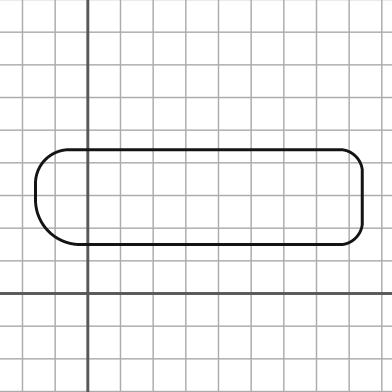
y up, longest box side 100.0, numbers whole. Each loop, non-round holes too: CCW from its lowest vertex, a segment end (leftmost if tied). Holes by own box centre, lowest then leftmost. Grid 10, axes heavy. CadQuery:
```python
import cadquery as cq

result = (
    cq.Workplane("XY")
    .moveTo(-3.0, 15.0)
    .lineTo(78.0, 15.0)
    .threePointArc((82.0, 17.0), (84.0, 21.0))
    .lineTo(84.0, 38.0)
    .threePointArc((82.0, 42.0), (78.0, 44.0))
    .lineTo(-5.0, 44.0)
    .threePointArc((-13.0, 41.0), (-16.0, 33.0))
    .lineTo(-16.0, 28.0)
    .threePointArc((-12.0, 19.0), (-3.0, 15.0))
    .close()
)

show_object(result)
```